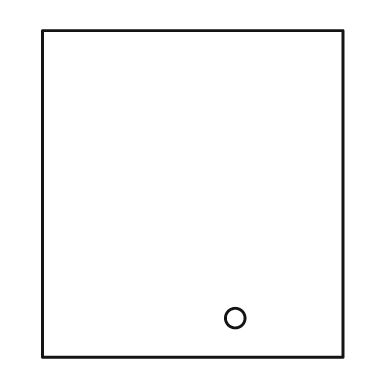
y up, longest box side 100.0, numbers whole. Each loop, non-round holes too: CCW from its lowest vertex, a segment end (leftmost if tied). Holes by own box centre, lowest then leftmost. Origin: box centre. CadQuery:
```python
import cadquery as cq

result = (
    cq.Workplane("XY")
    .moveTo(-46.0, -50.0)
    .lineTo(46.0, -50.0)
    .lineTo(46.0, 50.0)
    .lineTo(-46.0, 50.0)
    .close()
    .moveTo(13.0, -38.0)
    .circle(3.0)
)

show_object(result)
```